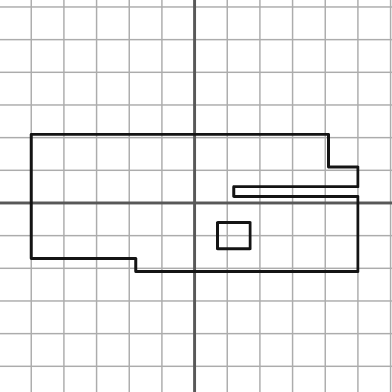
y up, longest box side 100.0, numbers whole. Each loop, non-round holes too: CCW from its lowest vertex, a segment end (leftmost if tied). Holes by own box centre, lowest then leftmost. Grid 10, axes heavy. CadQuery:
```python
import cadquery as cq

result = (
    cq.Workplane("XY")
    .moveTo(-18.0, -21.0)
    .lineTo(50.0, -21.0)
    .lineTo(50.0, 2.0)
    .lineTo(12.0, 2.0)
    .lineTo(12.0, 5.0)
    .lineTo(50.0, 5.0)
    .lineTo(50.0, 11.0)
    .lineTo(41.0, 11.0)
    .lineTo(41.0, 21.0)
    .lineTo(-50.0, 21.0)
    .lineTo(-50.0, -17.0)
    .lineTo(-18.0, -17.0)
    .close()
    .moveTo(7.0, -14.0)
    .lineTo(17.0, -14.0)
    .lineTo(17.0, -6.0)
    .lineTo(7.0, -6.0)
    .close()
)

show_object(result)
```